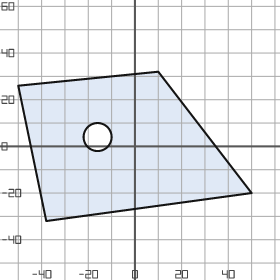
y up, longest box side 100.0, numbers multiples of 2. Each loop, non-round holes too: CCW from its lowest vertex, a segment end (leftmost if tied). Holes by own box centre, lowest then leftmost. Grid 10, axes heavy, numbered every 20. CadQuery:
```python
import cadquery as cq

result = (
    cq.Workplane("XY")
    .moveTo(-38.0, -32.0)
    .lineTo(50.0, -20.0)
    .lineTo(10.0, 32.0)
    .lineTo(-50.0, 26.0)
    .close()
    .moveTo(-16.0, 4.0)
    .circle(6.0)
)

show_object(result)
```